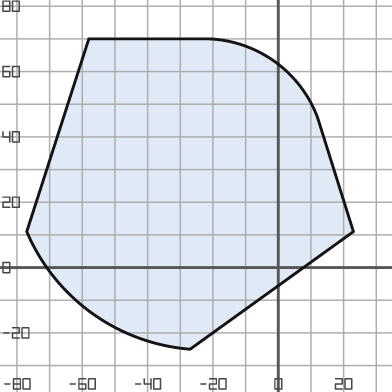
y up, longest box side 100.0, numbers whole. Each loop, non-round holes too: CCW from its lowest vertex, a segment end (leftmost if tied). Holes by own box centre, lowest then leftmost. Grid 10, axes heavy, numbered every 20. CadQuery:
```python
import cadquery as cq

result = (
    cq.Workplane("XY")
    .moveTo(-27.0, -25.0)
    .lineTo(23.0, 11.0)
    .lineTo(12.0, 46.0)
    .threePointArc((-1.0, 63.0), (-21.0, 70.0))
    .lineTo(-58.0, 70.0)
    .lineTo(-77.0, 11.0)
    .threePointArc((-57.0, -14.0), (-27.0, -25.0))
    .close()
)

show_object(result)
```